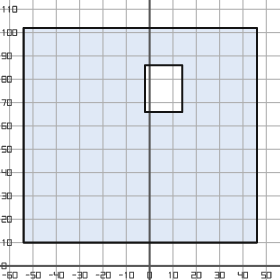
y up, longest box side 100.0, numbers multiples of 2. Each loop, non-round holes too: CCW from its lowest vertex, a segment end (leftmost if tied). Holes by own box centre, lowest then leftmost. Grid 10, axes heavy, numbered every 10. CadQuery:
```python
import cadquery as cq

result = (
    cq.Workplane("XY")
    .moveTo(-54.0, 10.0)
    .lineTo(46.0, 10.0)
    .lineTo(46.0, 102.0)
    .lineTo(-54.0, 102.0)
    .close()
    .moveTo(-2.0, 66.0)
    .lineTo(14.0, 66.0)
    .lineTo(14.0, 86.0)
    .lineTo(-2.0, 86.0)
    .close()
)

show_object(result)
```